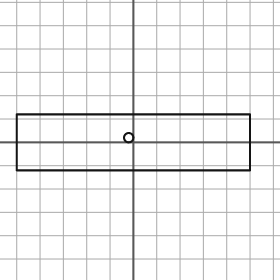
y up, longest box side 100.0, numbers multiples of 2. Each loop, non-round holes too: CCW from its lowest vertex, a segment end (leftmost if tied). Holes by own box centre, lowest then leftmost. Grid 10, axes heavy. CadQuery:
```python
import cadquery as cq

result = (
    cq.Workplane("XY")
    .moveTo(-50.0, -12.0)
    .lineTo(50.0, -12.0)
    .lineTo(50.0, 12.0)
    .lineTo(-50.0, 12.0)
    .close()
    .moveTo(-2.0, 2.0)
    .circle(2.0)
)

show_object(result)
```